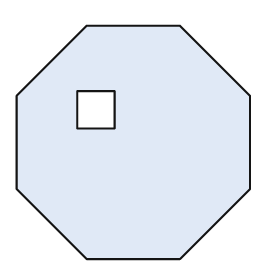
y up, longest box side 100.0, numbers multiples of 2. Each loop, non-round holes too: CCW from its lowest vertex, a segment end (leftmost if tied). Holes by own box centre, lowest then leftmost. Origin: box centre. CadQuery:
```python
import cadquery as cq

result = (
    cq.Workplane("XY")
    .moveTo(-20.0, -50.0)
    .lineTo(20.0, -50.0)
    .lineTo(50.0, -20.0)
    .lineTo(50.0, 20.0)
    .lineTo(20.0, 50.0)
    .lineTo(-20.0, 50.0)
    .lineTo(-50.0, 20.0)
    .lineTo(-50.0, -20.0)
    .close()
    .moveTo(-24.0, 6.0)
    .lineTo(-8.0, 6.0)
    .lineTo(-8.0, 22.0)
    .lineTo(-24.0, 22.0)
    .close()
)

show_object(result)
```